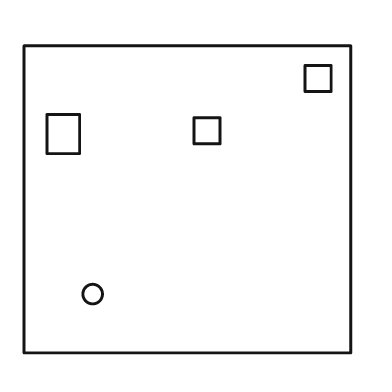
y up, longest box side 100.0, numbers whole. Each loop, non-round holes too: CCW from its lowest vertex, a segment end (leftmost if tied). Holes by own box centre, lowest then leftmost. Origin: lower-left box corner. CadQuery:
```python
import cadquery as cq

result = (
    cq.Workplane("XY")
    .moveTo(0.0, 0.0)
    .lineTo(100.0, 0.0)
    .lineTo(100.0, 94.0)
    .lineTo(0.0, 94.0)
    .close()
    .moveTo(21.0, 18.0)
    .circle(3.0)
    .moveTo(7.0, 61.0)
    .lineTo(17.0, 61.0)
    .lineTo(17.0, 73.0)
    .lineTo(7.0, 73.0)
    .close()
    .moveTo(52.0, 64.0)
    .lineTo(60.0, 64.0)
    .lineTo(60.0, 72.0)
    .lineTo(52.0, 72.0)
    .close()
    .moveTo(86.0, 80.0)
    .lineTo(94.0, 80.0)
    .lineTo(94.0, 88.0)
    .lineTo(86.0, 88.0)
    .close()
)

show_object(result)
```